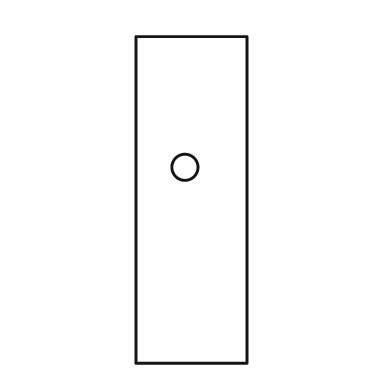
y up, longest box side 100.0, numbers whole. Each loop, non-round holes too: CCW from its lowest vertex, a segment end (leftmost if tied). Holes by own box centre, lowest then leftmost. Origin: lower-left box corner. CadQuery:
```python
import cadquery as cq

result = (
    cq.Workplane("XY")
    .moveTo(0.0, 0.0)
    .lineTo(34.0, 0.0)
    .lineTo(34.0, 100.0)
    .lineTo(0.0, 100.0)
    .close()
    .moveTo(15.0, 60.0)
    .circle(4.0)
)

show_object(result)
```